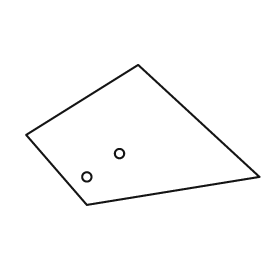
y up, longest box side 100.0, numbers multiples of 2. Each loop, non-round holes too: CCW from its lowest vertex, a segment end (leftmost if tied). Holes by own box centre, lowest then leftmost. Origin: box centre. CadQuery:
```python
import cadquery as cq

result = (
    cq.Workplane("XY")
    .moveTo(-24.0, -30.0)
    .lineTo(50.0, -18.0)
    .lineTo(-2.0, 30.0)
    .lineTo(-50.0, 0.0)
    .close()
    .moveTo(-24.0, -18.0)
    .circle(2.0)
    .moveTo(-10.0, -8.0)
    .circle(2.0)
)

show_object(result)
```